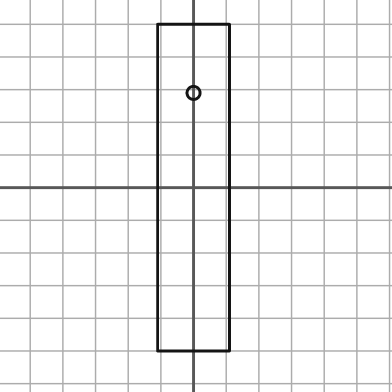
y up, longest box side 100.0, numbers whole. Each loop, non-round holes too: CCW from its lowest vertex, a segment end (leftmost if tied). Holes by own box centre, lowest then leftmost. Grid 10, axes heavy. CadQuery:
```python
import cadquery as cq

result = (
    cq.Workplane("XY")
    .moveTo(-11.0, -50.0)
    .lineTo(11.0, -50.0)
    .lineTo(11.0, 50.0)
    .lineTo(-11.0, 50.0)
    .close()
    .moveTo(0.0, 29.0)
    .circle(2.0)
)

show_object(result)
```